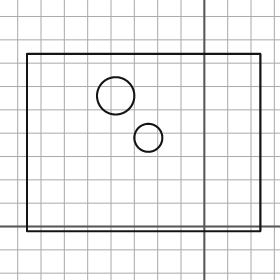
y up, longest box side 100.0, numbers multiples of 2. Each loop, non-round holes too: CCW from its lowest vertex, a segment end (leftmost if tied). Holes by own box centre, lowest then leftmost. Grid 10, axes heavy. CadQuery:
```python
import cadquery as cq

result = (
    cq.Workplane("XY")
    .moveTo(-76.0, -2.0)
    .lineTo(24.0, -2.0)
    .lineTo(24.0, 74.0)
    .lineTo(-76.0, 74.0)
    .close()
    .moveTo(-24.0, 38.0)
    .circle(6.0)
    .moveTo(-38.0, 56.0)
    .circle(8.0)
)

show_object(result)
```